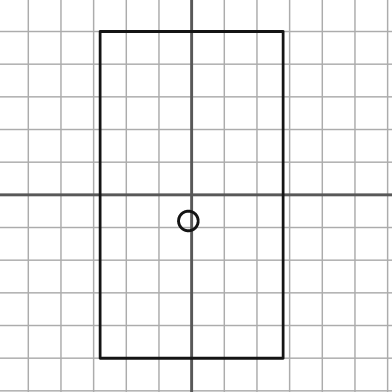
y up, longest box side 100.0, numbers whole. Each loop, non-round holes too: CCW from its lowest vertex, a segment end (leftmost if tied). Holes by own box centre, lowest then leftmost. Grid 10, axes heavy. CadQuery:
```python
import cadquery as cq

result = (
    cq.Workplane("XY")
    .moveTo(-28.0, -50.0)
    .lineTo(28.0, -50.0)
    .lineTo(28.0, 50.0)
    .lineTo(-28.0, 50.0)
    .close()
    .moveTo(-1.0, -8.0)
    .circle(3.0)
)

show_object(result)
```